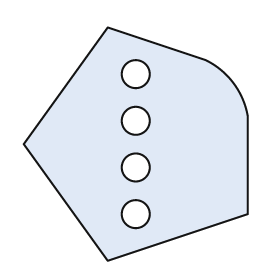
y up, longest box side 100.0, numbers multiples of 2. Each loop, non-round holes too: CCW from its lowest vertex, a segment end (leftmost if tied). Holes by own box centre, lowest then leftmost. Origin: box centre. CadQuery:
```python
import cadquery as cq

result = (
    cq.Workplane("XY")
    .moveTo(-12.0, -50.0)
    .lineTo(48.0, -30.0)
    .lineTo(48.0, 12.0)
    .threePointArc((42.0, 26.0), (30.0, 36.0))
    .lineTo(-12.0, 50.0)
    .lineTo(-48.0, 0.0)
    .close()
    .moveTo(0.0, -30.0)
    .circle(6.0)
    .moveTo(0.0, -10.0)
    .circle(6.0)
    .moveTo(0.0, 10.0)
    .circle(6.0)
    .moveTo(0.0, 30.0)
    .circle(6.0)
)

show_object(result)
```